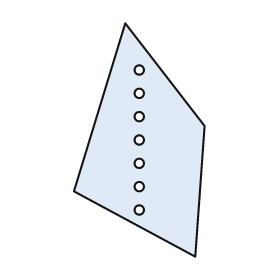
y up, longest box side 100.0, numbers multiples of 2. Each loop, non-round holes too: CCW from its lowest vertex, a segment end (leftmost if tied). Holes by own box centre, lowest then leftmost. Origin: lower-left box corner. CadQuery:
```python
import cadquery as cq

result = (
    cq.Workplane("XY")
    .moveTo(52.0, 0.0)
    .lineTo(56.0, 56.0)
    .lineTo(22.0, 100.0)
    .lineTo(0.0, 28.0)
    .close()
    .moveTo(28.0, 20.0)
    .circle(2.0)
    .moveTo(28.0, 30.0)
    .circle(2.0)
    .moveTo(28.0, 40.0)
    .circle(2.0)
    .moveTo(28.0, 50.0)
    .circle(2.0)
    .moveTo(28.0, 60.0)
    .circle(2.0)
    .moveTo(28.0, 70.0)
    .circle(2.0)
    .moveTo(28.0, 80.0)
    .circle(2.0)
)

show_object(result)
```